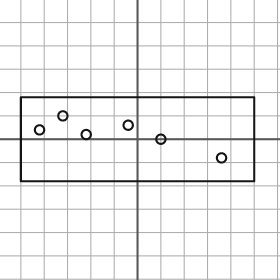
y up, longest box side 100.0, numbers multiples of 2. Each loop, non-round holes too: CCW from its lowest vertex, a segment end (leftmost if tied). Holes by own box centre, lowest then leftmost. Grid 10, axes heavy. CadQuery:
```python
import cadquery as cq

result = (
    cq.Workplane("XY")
    .moveTo(-50.0, -18.0)
    .lineTo(50.0, -18.0)
    .lineTo(50.0, 18.0)
    .lineTo(-50.0, 18.0)
    .close()
    .moveTo(36.0, -8.0)
    .circle(2.0)
    .moveTo(10.0, 0.0)
    .circle(2.0)
    .moveTo(-22.0, 2.0)
    .circle(2.0)
    .moveTo(-42.0, 4.0)
    .circle(2.0)
    .moveTo(-4.0, 6.0)
    .circle(2.0)
    .moveTo(-32.0, 10.0)
    .circle(2.0)
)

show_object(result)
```